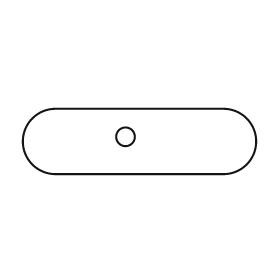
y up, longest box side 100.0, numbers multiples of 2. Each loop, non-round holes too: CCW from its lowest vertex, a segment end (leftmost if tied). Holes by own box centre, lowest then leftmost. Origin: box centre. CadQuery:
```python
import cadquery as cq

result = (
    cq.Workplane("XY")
    .moveTo(-36.0, -14.0)
    .lineTo(36.0, -14.0)
    .threePointArc((50.0, 0.0), (36.0, 14.0))
    .lineTo(-36.0, 14.0)
    .threePointArc((-50.0, 0.0), (-36.0, -14.0))
    .close()
    .moveTo(-6.0, 2.0)
    .circle(4.0)
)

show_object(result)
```